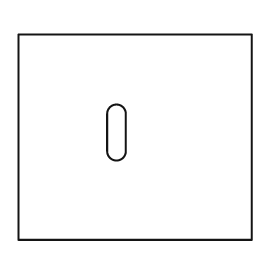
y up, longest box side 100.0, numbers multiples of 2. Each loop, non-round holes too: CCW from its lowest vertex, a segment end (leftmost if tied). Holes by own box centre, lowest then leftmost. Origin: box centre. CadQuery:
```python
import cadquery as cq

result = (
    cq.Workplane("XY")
    .moveTo(-50.0, -44.0)
    .lineTo(50.0, -44.0)
    .lineTo(50.0, 44.0)
    .lineTo(-50.0, 44.0)
    .close()
    .moveTo(-12.0, -6.0)
    .threePointArc((-8.0, -10.0), (-4.0, -6.0))
    .lineTo(-4.0, 10.0)
    .threePointArc((-8.0, 14.0), (-12.0, 10.0))
    .close()
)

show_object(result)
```